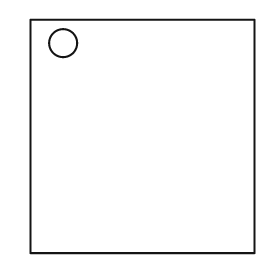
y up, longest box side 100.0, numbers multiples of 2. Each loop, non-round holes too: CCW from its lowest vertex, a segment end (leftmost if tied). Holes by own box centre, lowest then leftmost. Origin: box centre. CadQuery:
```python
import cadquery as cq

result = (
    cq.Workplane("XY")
    .moveTo(-48.0, -50.0)
    .lineTo(48.0, -50.0)
    .lineTo(48.0, 50.0)
    .lineTo(-48.0, 50.0)
    .close()
    .moveTo(-34.0, 40.0)
    .circle(6.0)
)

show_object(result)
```